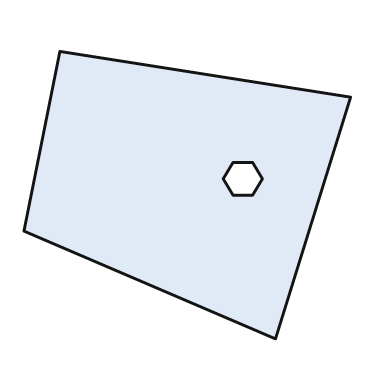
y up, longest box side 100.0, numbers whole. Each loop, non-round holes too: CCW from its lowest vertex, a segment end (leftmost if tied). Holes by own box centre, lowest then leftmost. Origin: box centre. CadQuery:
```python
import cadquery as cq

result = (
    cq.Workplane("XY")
    .moveTo(27.0, -44.0)
    .lineTo(50.0, 30.0)
    .lineTo(-39.0, 44.0)
    .lineTo(-50.0, -11.0)
    .close()
    .moveTo(14.0, 0.0)
    .lineTo(20.0, 0.0)
    .lineTo(23.0, 5.0)
    .lineTo(20.0, 10.0)
    .lineTo(14.0, 10.0)
    .lineTo(11.0, 5.0)
    .close()
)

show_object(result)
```